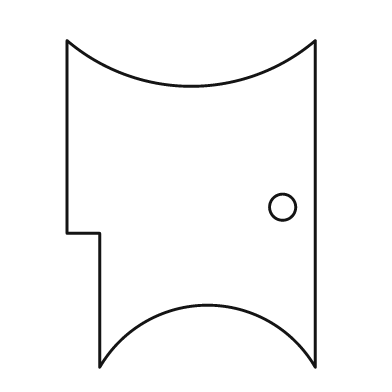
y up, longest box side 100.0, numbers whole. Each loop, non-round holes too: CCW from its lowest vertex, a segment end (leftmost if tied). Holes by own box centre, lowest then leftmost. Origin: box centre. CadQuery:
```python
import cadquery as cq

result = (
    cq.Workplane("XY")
    .moveTo(-28.0, -50.0)
    .threePointArc((5.0, -31.0), (38.0, -50.0))
    .lineTo(38.0, 50.0)
    .threePointArc((0.0, 36.0), (-38.0, 50.0))
    .lineTo(-38.0, -9.0)
    .lineTo(-28.0, -9.0)
    .close()
    .moveTo(28.0, -1.0)
    .circle(4.0)
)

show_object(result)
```